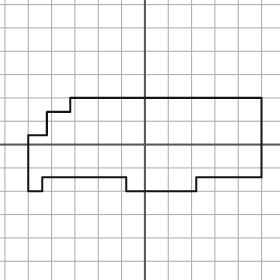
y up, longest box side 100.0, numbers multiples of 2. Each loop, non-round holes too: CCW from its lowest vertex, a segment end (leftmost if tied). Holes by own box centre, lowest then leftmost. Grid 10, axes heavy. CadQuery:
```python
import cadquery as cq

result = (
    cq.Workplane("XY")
    .moveTo(-50.0, -20.0)
    .lineTo(-44.0, -20.0)
    .lineTo(-44.0, -14.0)
    .lineTo(-8.0, -14.0)
    .lineTo(-8.0, -20.0)
    .lineTo(22.0, -20.0)
    .lineTo(22.0, -14.0)
    .lineTo(50.0, -14.0)
    .lineTo(50.0, 20.0)
    .lineTo(-32.0, 20.0)
    .lineTo(-32.0, 14.0)
    .lineTo(-42.0, 14.0)
    .lineTo(-42.0, 4.0)
    .lineTo(-50.0, 4.0)
    .close()
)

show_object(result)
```